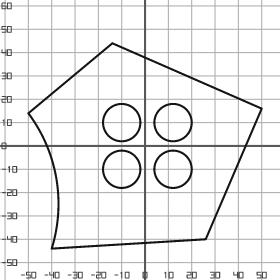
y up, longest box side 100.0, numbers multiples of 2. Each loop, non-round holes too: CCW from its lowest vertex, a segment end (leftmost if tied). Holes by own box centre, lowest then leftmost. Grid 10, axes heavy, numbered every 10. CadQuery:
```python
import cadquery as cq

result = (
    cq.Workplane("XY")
    .moveTo(-40.0, -44.0)
    .lineTo(26.0, -40.0)
    .lineTo(50.0, 16.0)
    .lineTo(-14.0, 44.0)
    .lineTo(-50.0, 14.0)
    .threePointArc((-38.0, -14.0), (-40.0, -44.0))
    .close()
    .moveTo(-10.0, -10.0)
    .circle(8.0)
    .moveTo(12.0, -10.0)
    .circle(8.0)
    .moveTo(-10.0, 10.0)
    .circle(8.0)
    .moveTo(12.0, 10.0)
    .circle(8.0)
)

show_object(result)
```